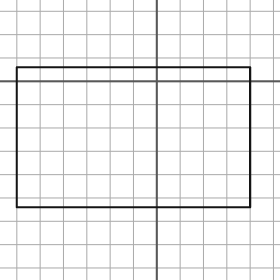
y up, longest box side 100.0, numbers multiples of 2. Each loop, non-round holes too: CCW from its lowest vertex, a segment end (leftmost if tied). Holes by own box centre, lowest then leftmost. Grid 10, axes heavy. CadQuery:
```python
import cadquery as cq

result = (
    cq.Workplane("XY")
    .moveTo(-60.0, -54.0)
    .lineTo(40.0, -54.0)
    .lineTo(40.0, 6.0)
    .lineTo(-60.0, 6.0)
    .close()
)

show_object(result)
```